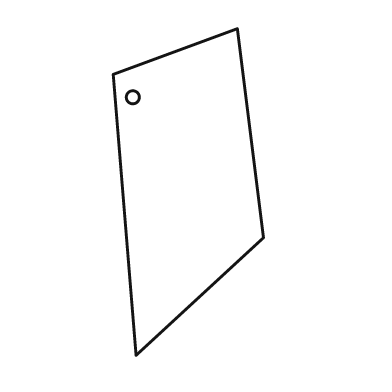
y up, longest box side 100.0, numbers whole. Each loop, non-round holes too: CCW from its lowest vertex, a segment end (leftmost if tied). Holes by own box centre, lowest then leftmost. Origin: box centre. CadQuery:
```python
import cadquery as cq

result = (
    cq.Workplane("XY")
    .moveTo(-16.0, -50.0)
    .lineTo(23.0, -14.0)
    .lineTo(15.0, 50.0)
    .lineTo(-23.0, 36.0)
    .close()
    .moveTo(-17.0, 29.0)
    .circle(2.0)
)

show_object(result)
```